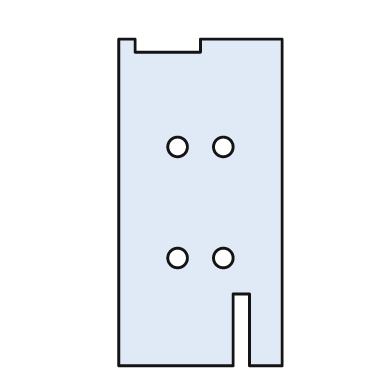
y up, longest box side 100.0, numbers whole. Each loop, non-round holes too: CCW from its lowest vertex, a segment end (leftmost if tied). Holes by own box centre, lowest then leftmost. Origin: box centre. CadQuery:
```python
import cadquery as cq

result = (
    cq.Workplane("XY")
    .moveTo(-25.0, -50.0)
    .lineTo(10.0, -50.0)
    .lineTo(10.0, -28.0)
    .lineTo(15.0, -28.0)
    .lineTo(15.0, -50.0)
    .lineTo(25.0, -50.0)
    .lineTo(25.0, 50.0)
    .lineTo(0.0, 50.0)
    .lineTo(0.0, 46.0)
    .lineTo(-20.0, 46.0)
    .lineTo(-20.0, 50.0)
    .lineTo(-25.0, 50.0)
    .close()
    .moveTo(-7.0, -17.0)
    .circle(3.0)
    .moveTo(7.0, -17.0)
    .circle(3.0)
    .moveTo(-7.0, 17.0)
    .circle(3.0)
    .moveTo(7.0, 17.0)
    .circle(3.0)
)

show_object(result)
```